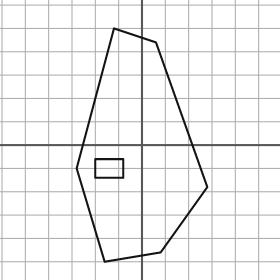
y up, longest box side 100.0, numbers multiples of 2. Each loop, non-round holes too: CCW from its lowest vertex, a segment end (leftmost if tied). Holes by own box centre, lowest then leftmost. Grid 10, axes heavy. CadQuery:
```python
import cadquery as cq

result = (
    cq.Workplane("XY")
    .moveTo(-16.0, -50.0)
    .lineTo(8.0, -46.0)
    .lineTo(28.0, -18.0)
    .lineTo(6.0, 44.0)
    .lineTo(-12.0, 50.0)
    .lineTo(-28.0, -10.0)
    .close()
    .moveTo(-20.0, -14.0)
    .lineTo(-8.0, -14.0)
    .lineTo(-8.0, -6.0)
    .lineTo(-20.0, -6.0)
    .close()
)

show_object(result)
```